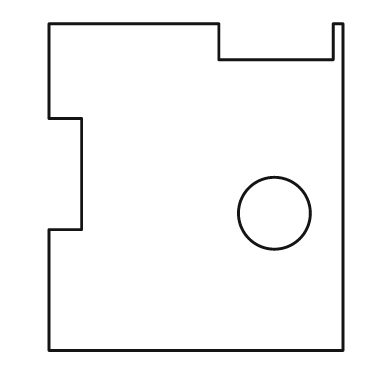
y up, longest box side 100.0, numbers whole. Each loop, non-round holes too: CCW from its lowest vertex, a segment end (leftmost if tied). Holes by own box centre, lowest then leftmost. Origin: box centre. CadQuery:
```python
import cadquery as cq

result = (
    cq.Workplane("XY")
    .moveTo(-45.0, -50.0)
    .lineTo(45.0, -50.0)
    .lineTo(45.0, 50.0)
    .lineTo(42.0, 50.0)
    .lineTo(42.0, 39.0)
    .lineTo(7.0, 39.0)
    .lineTo(7.0, 50.0)
    .lineTo(-45.0, 50.0)
    .lineTo(-45.0, 21.0)
    .lineTo(-35.0, 21.0)
    .lineTo(-35.0, -13.0)
    .lineTo(-45.0, -13.0)
    .close()
    .moveTo(24.0, -8.0)
    .circle(11.0)
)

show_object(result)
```